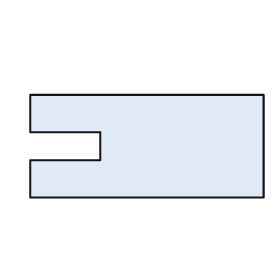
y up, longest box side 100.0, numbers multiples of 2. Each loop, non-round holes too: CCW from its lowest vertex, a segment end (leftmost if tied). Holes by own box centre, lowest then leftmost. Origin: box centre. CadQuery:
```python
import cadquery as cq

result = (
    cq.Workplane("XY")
    .moveTo(-50.0, -22.0)
    .lineTo(50.0, -22.0)
    .lineTo(50.0, 22.0)
    .lineTo(-50.0, 22.0)
    .lineTo(-50.0, 6.0)
    .lineTo(-20.0, 6.0)
    .lineTo(-20.0, -6.0)
    .lineTo(-50.0, -6.0)
    .close()
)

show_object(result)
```